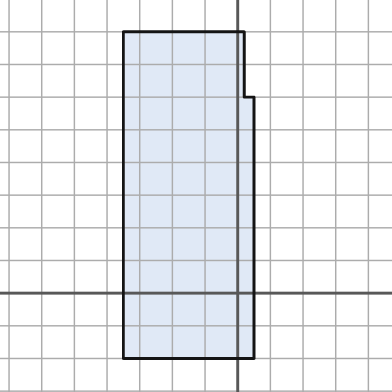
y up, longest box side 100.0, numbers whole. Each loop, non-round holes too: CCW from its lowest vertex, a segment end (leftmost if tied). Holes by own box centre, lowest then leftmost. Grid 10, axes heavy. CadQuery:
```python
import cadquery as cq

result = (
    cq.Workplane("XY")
    .moveTo(-35.0, -20.0)
    .lineTo(5.0, -20.0)
    .lineTo(5.0, 60.0)
    .lineTo(2.0, 60.0)
    .lineTo(2.0, 80.0)
    .lineTo(-35.0, 80.0)
    .close()
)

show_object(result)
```